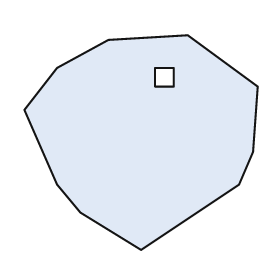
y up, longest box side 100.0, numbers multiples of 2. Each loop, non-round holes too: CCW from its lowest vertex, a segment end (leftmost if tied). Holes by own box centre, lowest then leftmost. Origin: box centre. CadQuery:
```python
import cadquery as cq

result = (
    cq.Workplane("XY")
    .moveTo(0.0, -46.0)
    .lineTo(42.0, -18.0)
    .lineTo(48.0, -4.0)
    .lineTo(50.0, 24.0)
    .lineTo(20.0, 46.0)
    .lineTo(-14.0, 44.0)
    .lineTo(-36.0, 32.0)
    .lineTo(-50.0, 14.0)
    .lineTo(-36.0, -18.0)
    .lineTo(-26.0, -30.0)
    .close()
    .moveTo(6.0, 24.0)
    .lineTo(14.0, 24.0)
    .lineTo(14.0, 32.0)
    .lineTo(6.0, 32.0)
    .close()
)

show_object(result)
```